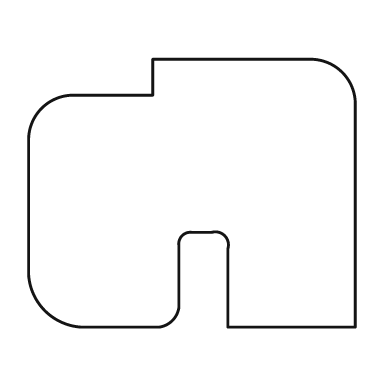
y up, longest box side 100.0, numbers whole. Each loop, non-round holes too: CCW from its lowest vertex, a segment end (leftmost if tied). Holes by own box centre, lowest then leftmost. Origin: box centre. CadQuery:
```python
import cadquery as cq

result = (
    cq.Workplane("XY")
    .moveTo(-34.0, -41.0)
    .lineTo(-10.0, -41.0)
    .threePointArc((-6.0, -39.0), (-4.0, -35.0))
    .lineTo(-4.0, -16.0)
    .threePointArc((-3.0, -13.0), (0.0, -12.0))
    .lineTo(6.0, -12.0)
    .threePointArc((10.0, -13.0), (11.0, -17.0))
    .lineTo(11.0, -41.0)
    .lineTo(50.0, -41.0)
    .lineTo(50.0, 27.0)
    .threePointArc((46.0, 37.0), (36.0, 41.0))
    .lineTo(-12.0, 41.0)
    .lineTo(-12.0, 30.0)
    .lineTo(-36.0, 30.0)
    .threePointArc((-46.0, 26.0), (-50.0, 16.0))
    .lineTo(-50.0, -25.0)
    .threePointArc((-45.0, -36.0), (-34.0, -41.0))
    .close()
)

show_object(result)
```